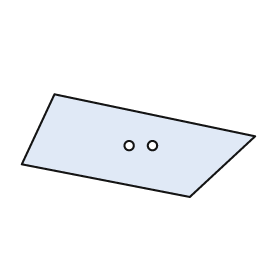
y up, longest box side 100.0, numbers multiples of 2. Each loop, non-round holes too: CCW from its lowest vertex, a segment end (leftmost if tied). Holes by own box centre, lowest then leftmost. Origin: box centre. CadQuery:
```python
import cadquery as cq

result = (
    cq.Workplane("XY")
    .moveTo(22.0, -22.0)
    .lineTo(50.0, 4.0)
    .lineTo(-36.0, 22.0)
    .lineTo(-50.0, -8.0)
    .close()
    .moveTo(-4.0, 0.0)
    .circle(2.0)
    .moveTo(6.0, 0.0)
    .circle(2.0)
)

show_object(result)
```